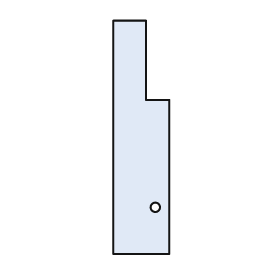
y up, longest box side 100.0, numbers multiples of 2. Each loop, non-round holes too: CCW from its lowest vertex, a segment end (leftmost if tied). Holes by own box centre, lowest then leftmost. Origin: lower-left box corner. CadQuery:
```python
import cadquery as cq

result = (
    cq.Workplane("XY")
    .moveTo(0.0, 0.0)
    .lineTo(24.0, 0.0)
    .lineTo(24.0, 66.0)
    .lineTo(14.0, 66.0)
    .lineTo(14.0, 100.0)
    .lineTo(0.0, 100.0)
    .close()
    .moveTo(18.0, 20.0)
    .circle(2.0)
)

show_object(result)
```